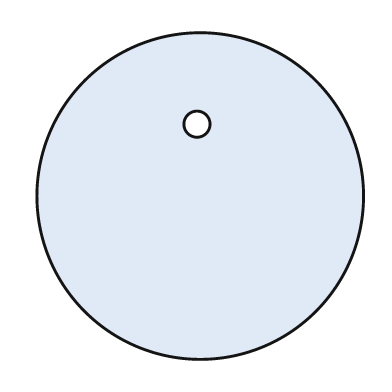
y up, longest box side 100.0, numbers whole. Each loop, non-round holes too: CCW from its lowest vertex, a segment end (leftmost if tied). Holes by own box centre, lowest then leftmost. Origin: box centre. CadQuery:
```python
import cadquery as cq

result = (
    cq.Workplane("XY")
    .moveTo(0.0, 0.0)
    .circle(50.0)
    .moveTo(-1.0, 22.0)
    .circle(4.0)
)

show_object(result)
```